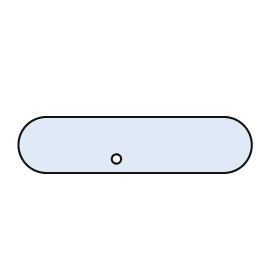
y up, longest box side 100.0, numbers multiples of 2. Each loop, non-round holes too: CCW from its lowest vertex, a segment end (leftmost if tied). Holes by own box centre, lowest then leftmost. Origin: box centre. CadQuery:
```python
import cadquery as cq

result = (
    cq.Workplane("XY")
    .moveTo(-38.0, -12.0)
    .lineTo(38.0, -12.0)
    .threePointArc((50.0, 0.0), (38.0, 12.0))
    .lineTo(-38.0, 12.0)
    .threePointArc((-50.0, 0.0), (-38.0, -12.0))
    .close()
    .moveTo(-8.0, -6.0)
    .circle(2.0)
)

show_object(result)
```